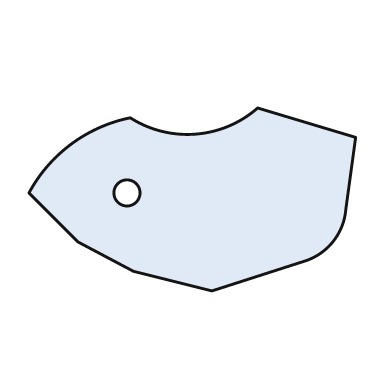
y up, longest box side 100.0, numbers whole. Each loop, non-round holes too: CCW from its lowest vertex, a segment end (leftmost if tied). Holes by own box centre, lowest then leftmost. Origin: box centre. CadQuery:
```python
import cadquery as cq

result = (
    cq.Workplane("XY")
    .moveTo(6.0, -28.0)
    .lineTo(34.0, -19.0)
    .threePointArc((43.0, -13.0), (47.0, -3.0))
    .lineTo(50.0, 19.0)
    .lineTo(20.0, 28.0)
    .threePointArc((1.0, 20.0), (-19.0, 25.0))
    .threePointArc((-37.0, 17.0), (-50.0, 2.0))
    .lineTo(-35.0, -13.0)
    .lineTo(-18.0, -22.0)
    .close()
    .moveTo(-20.0, 2.0)
    .circle(4.0)
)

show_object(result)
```